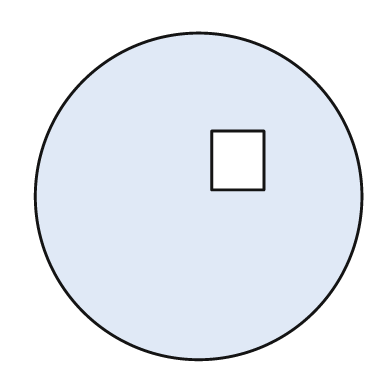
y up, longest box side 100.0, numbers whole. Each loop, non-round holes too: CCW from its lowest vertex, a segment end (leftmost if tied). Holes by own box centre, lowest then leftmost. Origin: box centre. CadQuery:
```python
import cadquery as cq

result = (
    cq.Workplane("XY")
    .moveTo(0.0, 0.0)
    .circle(50.0)
    .moveTo(4.0, 2.0)
    .lineTo(20.0, 2.0)
    .lineTo(20.0, 20.0)
    .lineTo(4.0, 20.0)
    .close()
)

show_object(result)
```